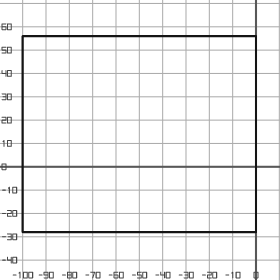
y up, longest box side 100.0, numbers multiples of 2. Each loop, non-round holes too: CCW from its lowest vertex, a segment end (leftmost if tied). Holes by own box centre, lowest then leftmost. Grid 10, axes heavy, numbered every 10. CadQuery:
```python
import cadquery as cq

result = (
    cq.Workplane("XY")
    .moveTo(-100.0, -28.0)
    .lineTo(0.0, -28.0)
    .lineTo(0.0, 56.0)
    .lineTo(-100.0, 56.0)
    .close()
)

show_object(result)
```